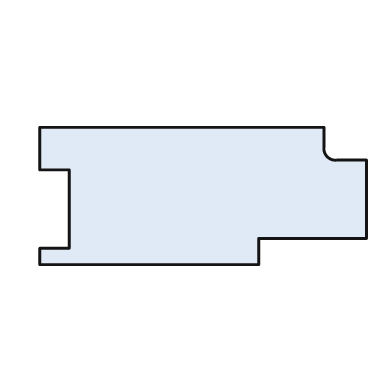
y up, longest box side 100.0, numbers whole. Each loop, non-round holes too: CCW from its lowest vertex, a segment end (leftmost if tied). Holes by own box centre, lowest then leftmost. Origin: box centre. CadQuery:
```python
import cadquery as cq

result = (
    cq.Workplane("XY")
    .moveTo(-50.0, -21.0)
    .lineTo(17.0, -21.0)
    .lineTo(17.0, -13.0)
    .lineTo(50.0, -13.0)
    .lineTo(50.0, 11.0)
    .lineTo(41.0, 11.0)
    .threePointArc((38.0, 12.0), (37.0, 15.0))
    .lineTo(37.0, 21.0)
    .lineTo(-50.0, 21.0)
    .lineTo(-50.0, 8.0)
    .lineTo(-41.0, 8.0)
    .lineTo(-41.0, -16.0)
    .lineTo(-50.0, -16.0)
    .close()
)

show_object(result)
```